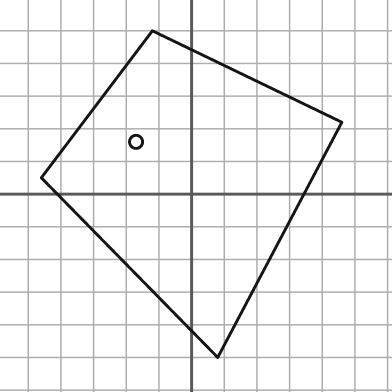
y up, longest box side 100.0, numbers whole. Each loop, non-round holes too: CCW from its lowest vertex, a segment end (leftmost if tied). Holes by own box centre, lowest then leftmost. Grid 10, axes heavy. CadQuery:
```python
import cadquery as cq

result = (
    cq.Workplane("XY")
    .moveTo(8.0, -50.0)
    .lineTo(46.0, 22.0)
    .lineTo(-12.0, 50.0)
    .lineTo(-46.0, 5.0)
    .close()
    .moveTo(-17.0, 16.0)
    .circle(2.0)
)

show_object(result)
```